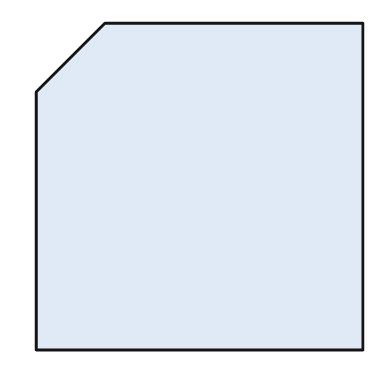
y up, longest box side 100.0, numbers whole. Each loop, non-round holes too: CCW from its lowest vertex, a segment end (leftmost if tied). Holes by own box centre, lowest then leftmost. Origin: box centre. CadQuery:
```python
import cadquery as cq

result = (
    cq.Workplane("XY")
    .moveTo(-50.0, -50.0)
    .lineTo(50.0, -50.0)
    .lineTo(50.0, 50.0)
    .lineTo(-29.0, 50.0)
    .lineTo(-50.0, 29.0)
    .close()
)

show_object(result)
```